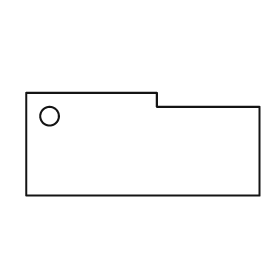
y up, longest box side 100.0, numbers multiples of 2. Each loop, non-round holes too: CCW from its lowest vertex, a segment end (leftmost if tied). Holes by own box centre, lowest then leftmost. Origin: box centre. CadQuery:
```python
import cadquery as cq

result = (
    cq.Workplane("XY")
    .moveTo(-50.0, -22.0)
    .lineTo(50.0, -22.0)
    .lineTo(50.0, 16.0)
    .lineTo(6.0, 16.0)
    .lineTo(6.0, 22.0)
    .lineTo(-50.0, 22.0)
    .close()
    .moveTo(-40.0, 12.0)
    .circle(4.0)
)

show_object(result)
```